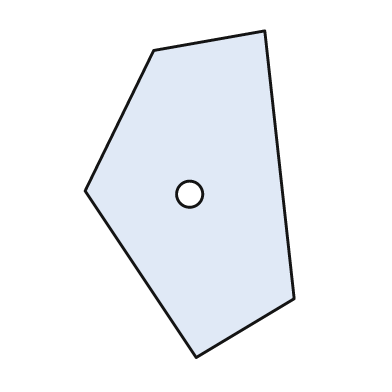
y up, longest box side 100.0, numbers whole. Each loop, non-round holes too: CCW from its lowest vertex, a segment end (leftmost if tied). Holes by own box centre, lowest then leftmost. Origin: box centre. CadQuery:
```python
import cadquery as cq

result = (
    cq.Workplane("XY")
    .moveTo(2.0, -50.0)
    .lineTo(32.0, -32.0)
    .lineTo(23.0, 50.0)
    .lineTo(-11.0, 44.0)
    .lineTo(-32.0, 1.0)
    .close()
    .moveTo(0.0, 0.0)
    .circle(4.0)
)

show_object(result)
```